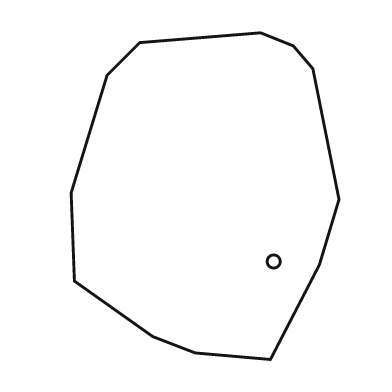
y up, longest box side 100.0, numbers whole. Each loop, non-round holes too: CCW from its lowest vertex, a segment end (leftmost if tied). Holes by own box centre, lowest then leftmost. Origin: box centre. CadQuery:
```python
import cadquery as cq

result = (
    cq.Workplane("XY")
    .moveTo(20.0, -50.0)
    .lineTo(35.0, -21.0)
    .lineTo(41.0, -1.0)
    .lineTo(33.0, 39.0)
    .lineTo(27.0, 46.0)
    .lineTo(17.0, 50.0)
    .lineTo(-20.0, 47.0)
    .lineTo(-30.0, 37.0)
    .lineTo(-41.0, 1.0)
    .lineTo(-40.0, -26.0)
    .lineTo(-16.0, -43.0)
    .lineTo(-3.0, -48.0)
    .close()
    .moveTo(21.0, -20.0)
    .circle(2.0)
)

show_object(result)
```